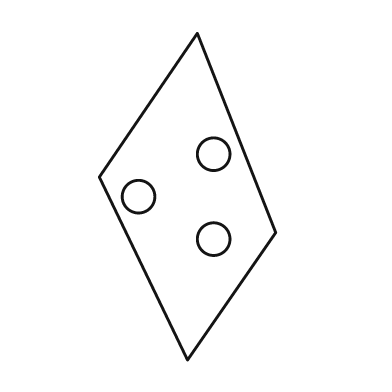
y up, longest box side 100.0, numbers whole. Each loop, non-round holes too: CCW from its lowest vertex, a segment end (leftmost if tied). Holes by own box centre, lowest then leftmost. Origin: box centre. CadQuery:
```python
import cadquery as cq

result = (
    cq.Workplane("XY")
    .moveTo(0.0, -50.0)
    .lineTo(27.0, -11.0)
    .lineTo(3.0, 50.0)
    .lineTo(-27.0, 6.0)
    .close()
    .moveTo(8.0, -13.0)
    .circle(5.0)
    .moveTo(-15.0, 0.0)
    .circle(5.0)
    .moveTo(8.0, 13.0)
    .circle(5.0)
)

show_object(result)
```